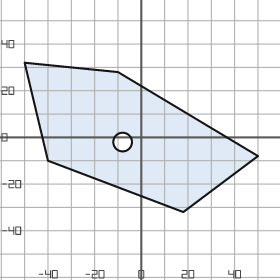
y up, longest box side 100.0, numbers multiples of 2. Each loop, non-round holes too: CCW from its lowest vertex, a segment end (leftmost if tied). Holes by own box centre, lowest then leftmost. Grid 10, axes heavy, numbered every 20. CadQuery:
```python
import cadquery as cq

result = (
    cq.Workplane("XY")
    .moveTo(18.0, -32.0)
    .lineTo(50.0, -8.0)
    .lineTo(-10.0, 28.0)
    .lineTo(-50.0, 32.0)
    .lineTo(-40.0, -10.0)
    .close()
    .moveTo(-8.0, -2.0)
    .circle(4.0)
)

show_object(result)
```